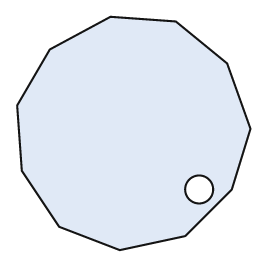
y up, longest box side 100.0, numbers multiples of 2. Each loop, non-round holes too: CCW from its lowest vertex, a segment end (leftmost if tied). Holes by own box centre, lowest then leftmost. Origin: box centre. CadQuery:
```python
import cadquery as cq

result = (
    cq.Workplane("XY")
    .moveTo(-6.0, -50.0)
    .lineTo(22.0, -44.0)
    .lineTo(42.0, -24.0)
    .lineTo(50.0, 2.0)
    .lineTo(40.0, 30.0)
    .lineTo(18.0, 48.0)
    .lineTo(-10.0, 50.0)
    .lineTo(-36.0, 36.0)
    .lineTo(-50.0, 12.0)
    .lineTo(-48.0, -16.0)
    .lineTo(-32.0, -40.0)
    .close()
    .moveTo(28.0, -24.0)
    .circle(6.0)
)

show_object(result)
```